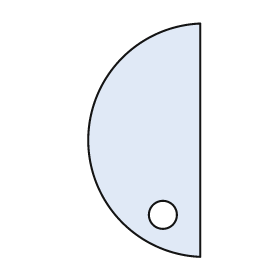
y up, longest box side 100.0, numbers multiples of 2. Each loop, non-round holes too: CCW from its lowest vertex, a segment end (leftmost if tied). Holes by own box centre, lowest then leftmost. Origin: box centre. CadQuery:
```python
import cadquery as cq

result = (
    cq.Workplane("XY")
    .moveTo(24.0, -50.0)
    .lineTo(24.0, 50.0)
    .threePointArc((-24.0, 0.0), (24.0, -50.0))
    .close()
    .moveTo(8.0, -32.0)
    .circle(6.0)
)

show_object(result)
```